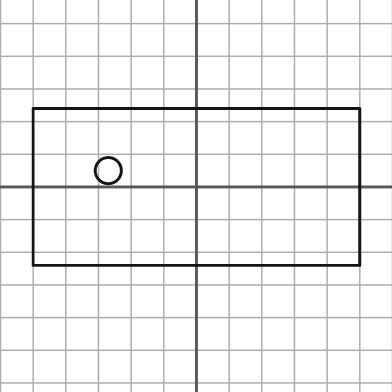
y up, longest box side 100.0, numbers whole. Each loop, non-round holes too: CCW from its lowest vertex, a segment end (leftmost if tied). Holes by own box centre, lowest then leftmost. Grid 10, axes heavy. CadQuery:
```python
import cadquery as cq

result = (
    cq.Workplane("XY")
    .moveTo(-50.0, -24.0)
    .lineTo(50.0, -24.0)
    .lineTo(50.0, 24.0)
    .lineTo(-50.0, 24.0)
    .close()
    .moveTo(-27.0, 5.0)
    .circle(4.0)
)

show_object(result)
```